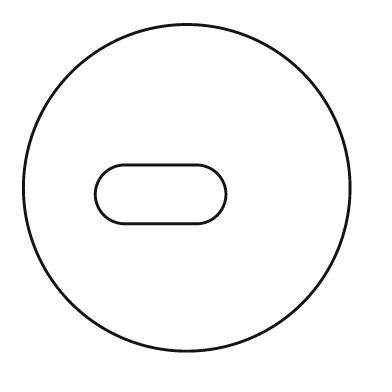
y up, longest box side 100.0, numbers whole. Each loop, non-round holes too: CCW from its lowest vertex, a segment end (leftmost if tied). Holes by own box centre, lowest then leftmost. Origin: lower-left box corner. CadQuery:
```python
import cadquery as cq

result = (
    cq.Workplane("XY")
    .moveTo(50.0, 50.0)
    .circle(50.0)
    .moveTo(31.0, 39.0)
    .lineTo(53.0, 39.0)
    .threePointArc((62.0, 48.0), (53.0, 57.0))
    .lineTo(31.0, 57.0)
    .threePointArc((22.0, 48.0), (31.0, 39.0))
    .close()
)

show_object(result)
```